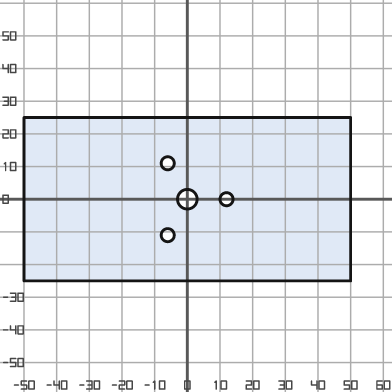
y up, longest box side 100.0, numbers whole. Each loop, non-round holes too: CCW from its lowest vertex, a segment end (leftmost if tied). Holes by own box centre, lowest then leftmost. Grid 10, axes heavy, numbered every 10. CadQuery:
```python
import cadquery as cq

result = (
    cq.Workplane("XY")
    .moveTo(-50.0, -25.0)
    .lineTo(50.0, -25.0)
    .lineTo(50.0, 25.0)
    .lineTo(-50.0, 25.0)
    .close()
    .moveTo(-6.0, -11.0)
    .circle(2.0)
    .moveTo(0.0, 0.0)
    .circle(3.0)
    .moveTo(12.0, 0.0)
    .circle(2.0)
    .moveTo(-6.0, 11.0)
    .circle(2.0)
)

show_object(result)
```